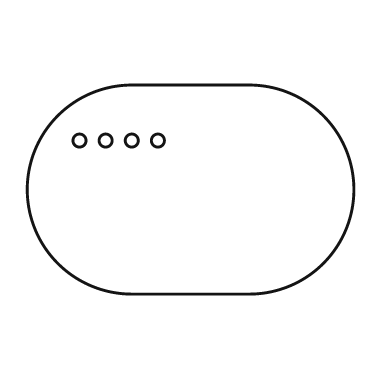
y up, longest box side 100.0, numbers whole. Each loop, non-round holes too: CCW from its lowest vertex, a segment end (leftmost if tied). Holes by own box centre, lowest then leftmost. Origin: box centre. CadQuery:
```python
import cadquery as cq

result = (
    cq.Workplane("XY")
    .moveTo(-18.0, -32.0)
    .lineTo(18.0, -32.0)
    .threePointArc((50.0, 0.0), (18.0, 32.0))
    .lineTo(-18.0, 32.0)
    .threePointArc((-50.0, 0.0), (-18.0, -32.0))
    .close()
    .moveTo(-34.0, 15.0)
    .circle(2.0)
    .moveTo(-26.0, 15.0)
    .circle(2.0)
    .moveTo(-18.0, 15.0)
    .circle(2.0)
    .moveTo(-10.0, 15.0)
    .circle(2.0)
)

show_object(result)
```